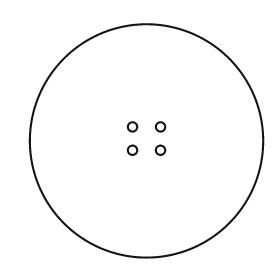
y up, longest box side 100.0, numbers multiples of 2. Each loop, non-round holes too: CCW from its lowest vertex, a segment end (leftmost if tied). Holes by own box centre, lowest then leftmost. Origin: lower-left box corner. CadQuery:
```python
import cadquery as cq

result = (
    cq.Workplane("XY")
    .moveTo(50.0, 50.0)
    .circle(50.0)
    .moveTo(44.0, 46.0)
    .circle(2.0)
    .moveTo(56.0, 46.0)
    .circle(2.0)
    .moveTo(44.0, 56.0)
    .circle(2.0)
    .moveTo(56.0, 56.0)
    .circle(2.0)
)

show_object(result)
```